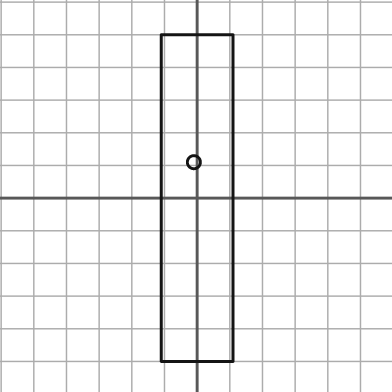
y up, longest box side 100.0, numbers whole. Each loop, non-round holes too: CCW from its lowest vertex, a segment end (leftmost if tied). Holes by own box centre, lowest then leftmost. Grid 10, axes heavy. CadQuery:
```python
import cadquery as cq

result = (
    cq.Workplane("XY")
    .moveTo(-11.0, -50.0)
    .lineTo(11.0, -50.0)
    .lineTo(11.0, 50.0)
    .lineTo(-11.0, 50.0)
    .close()
    .moveTo(-1.0, 11.0)
    .circle(2.0)
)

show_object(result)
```